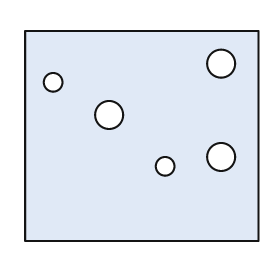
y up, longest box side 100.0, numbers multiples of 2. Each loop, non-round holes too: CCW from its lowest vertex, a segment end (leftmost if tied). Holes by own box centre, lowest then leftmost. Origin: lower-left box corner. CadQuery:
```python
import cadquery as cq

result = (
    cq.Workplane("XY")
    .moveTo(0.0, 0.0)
    .lineTo(100.0, 0.0)
    .lineTo(100.0, 90.0)
    .lineTo(0.0, 90.0)
    .close()
    .moveTo(60.0, 32.0)
    .circle(4.0)
    .moveTo(84.0, 36.0)
    .circle(6.0)
    .moveTo(36.0, 54.0)
    .circle(6.0)
    .moveTo(12.0, 68.0)
    .circle(4.0)
    .moveTo(84.0, 76.0)
    .circle(6.0)
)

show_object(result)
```